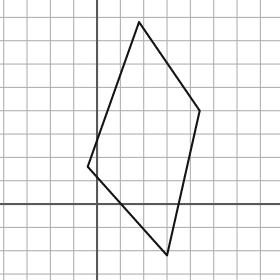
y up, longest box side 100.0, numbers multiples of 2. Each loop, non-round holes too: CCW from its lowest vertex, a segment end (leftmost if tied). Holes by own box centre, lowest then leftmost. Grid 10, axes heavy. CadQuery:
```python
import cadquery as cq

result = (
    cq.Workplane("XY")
    .moveTo(30.0, -22.0)
    .lineTo(44.0, 40.0)
    .lineTo(18.0, 78.0)
    .lineTo(-4.0, 16.0)
    .close()
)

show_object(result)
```